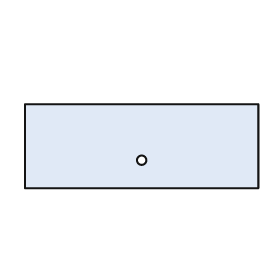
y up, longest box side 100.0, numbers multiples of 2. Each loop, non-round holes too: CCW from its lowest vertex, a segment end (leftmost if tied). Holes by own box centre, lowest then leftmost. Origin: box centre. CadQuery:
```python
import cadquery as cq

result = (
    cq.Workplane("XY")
    .moveTo(-50.0, -18.0)
    .lineTo(50.0, -18.0)
    .lineTo(50.0, 18.0)
    .lineTo(-50.0, 18.0)
    .close()
    .moveTo(0.0, -6.0)
    .circle(2.0)
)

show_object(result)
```